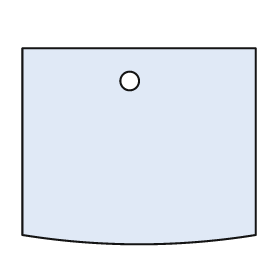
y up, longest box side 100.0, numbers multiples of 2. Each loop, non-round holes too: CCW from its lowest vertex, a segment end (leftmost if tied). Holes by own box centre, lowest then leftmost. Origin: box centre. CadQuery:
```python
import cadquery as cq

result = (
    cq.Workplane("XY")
    .moveTo(-50.0, -38.0)
    .threePointArc((0.0, -42.0), (50.0, -38.0))
    .lineTo(50.0, 42.0)
    .lineTo(-50.0, 42.0)
    .close()
    .moveTo(-4.0, 28.0)
    .circle(4.0)
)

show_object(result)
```